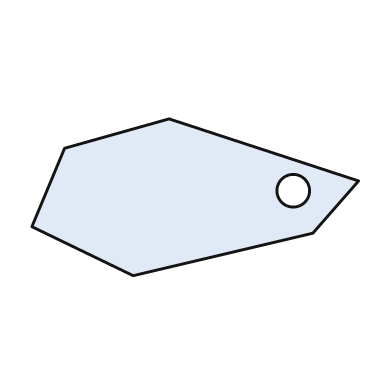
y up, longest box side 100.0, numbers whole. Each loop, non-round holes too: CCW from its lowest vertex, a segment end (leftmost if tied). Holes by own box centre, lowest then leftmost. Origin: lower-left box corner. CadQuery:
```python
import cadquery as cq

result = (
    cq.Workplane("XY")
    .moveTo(31.0, 0.0)
    .lineTo(86.0, 13.0)
    .lineTo(100.0, 29.0)
    .lineTo(42.0, 48.0)
    .lineTo(10.0, 39.0)
    .lineTo(0.0, 15.0)
    .close()
    .moveTo(80.0, 26.0)
    .circle(5.0)
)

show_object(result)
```